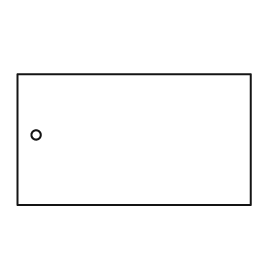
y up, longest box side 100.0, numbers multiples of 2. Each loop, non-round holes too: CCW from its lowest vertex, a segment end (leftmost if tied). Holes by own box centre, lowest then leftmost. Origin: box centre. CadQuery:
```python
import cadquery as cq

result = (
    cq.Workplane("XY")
    .moveTo(-50.0, -28.0)
    .lineTo(50.0, -28.0)
    .lineTo(50.0, 28.0)
    .lineTo(-50.0, 28.0)
    .close()
    .moveTo(-42.0, 2.0)
    .circle(2.0)
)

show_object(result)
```